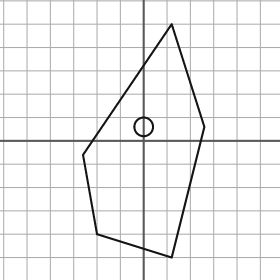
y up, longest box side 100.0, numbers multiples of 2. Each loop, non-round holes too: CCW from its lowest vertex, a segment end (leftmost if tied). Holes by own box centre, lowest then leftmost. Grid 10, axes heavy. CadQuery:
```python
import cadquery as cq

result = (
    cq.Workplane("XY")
    .moveTo(12.0, -50.0)
    .lineTo(26.0, 6.0)
    .lineTo(12.0, 50.0)
    .lineTo(-26.0, -6.0)
    .lineTo(-20.0, -40.0)
    .close()
    .moveTo(0.0, 6.0)
    .circle(4.0)
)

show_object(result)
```